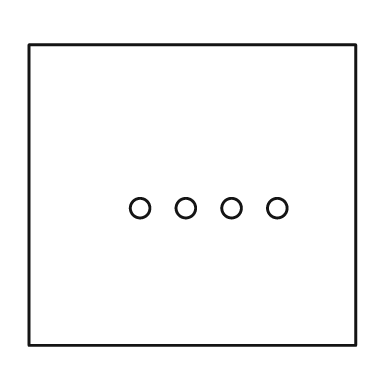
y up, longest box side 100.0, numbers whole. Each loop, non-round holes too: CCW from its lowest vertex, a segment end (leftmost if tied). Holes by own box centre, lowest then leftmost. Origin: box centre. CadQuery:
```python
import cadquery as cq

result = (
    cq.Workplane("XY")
    .moveTo(-50.0, -46.0)
    .lineTo(50.0, -46.0)
    .lineTo(50.0, 46.0)
    .lineTo(-50.0, 46.0)
    .close()
    .moveTo(-16.0, -4.0)
    .circle(3.0)
    .moveTo(-2.0, -4.0)
    .circle(3.0)
    .moveTo(12.0, -4.0)
    .circle(3.0)
    .moveTo(26.0, -4.0)
    .circle(3.0)
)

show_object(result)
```